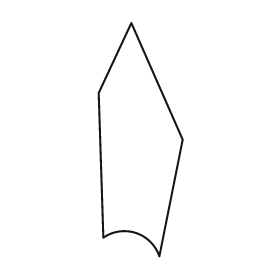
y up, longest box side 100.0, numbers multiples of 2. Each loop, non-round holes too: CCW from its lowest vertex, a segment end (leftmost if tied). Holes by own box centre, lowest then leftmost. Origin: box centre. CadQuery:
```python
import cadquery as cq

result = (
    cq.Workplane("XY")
    .moveTo(8.0, -50.0)
    .lineTo(18.0, 0.0)
    .lineTo(-4.0, 50.0)
    .lineTo(-18.0, 20.0)
    .lineTo(-16.0, -42.0)
    .threePointArc((-2.0, -40.0), (8.0, -50.0))
    .close()
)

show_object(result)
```